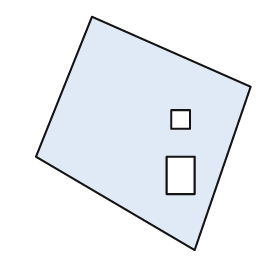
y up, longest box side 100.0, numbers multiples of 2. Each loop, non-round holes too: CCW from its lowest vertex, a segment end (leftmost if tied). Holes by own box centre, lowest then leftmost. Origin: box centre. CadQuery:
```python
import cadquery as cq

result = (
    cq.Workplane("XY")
    .moveTo(22.0, -50.0)
    .lineTo(46.0, 20.0)
    .lineTo(-22.0, 50.0)
    .lineTo(-46.0, -10.0)
    .close()
    .moveTo(10.0, -26.0)
    .lineTo(22.0, -26.0)
    .lineTo(22.0, -10.0)
    .lineTo(10.0, -10.0)
    .close()
    .moveTo(12.0, 2.0)
    .lineTo(20.0, 2.0)
    .lineTo(20.0, 10.0)
    .lineTo(12.0, 10.0)
    .close()
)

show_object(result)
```